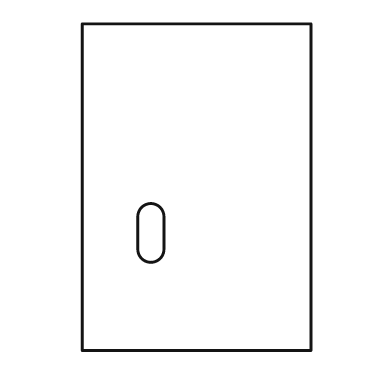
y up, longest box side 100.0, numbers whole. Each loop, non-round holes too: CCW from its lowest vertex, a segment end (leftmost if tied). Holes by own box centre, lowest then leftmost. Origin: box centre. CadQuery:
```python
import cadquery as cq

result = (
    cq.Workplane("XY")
    .moveTo(-35.0, -50.0)
    .lineTo(35.0, -50.0)
    .lineTo(35.0, 50.0)
    .lineTo(-35.0, 50.0)
    .close()
    .moveTo(-18.0, -19.0)
    .threePointArc((-14.0, -23.0), (-10.0, -19.0))
    .lineTo(-10.0, -9.0)
    .threePointArc((-14.0, -5.0), (-18.0, -9.0))
    .close()
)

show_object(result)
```